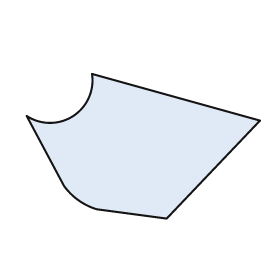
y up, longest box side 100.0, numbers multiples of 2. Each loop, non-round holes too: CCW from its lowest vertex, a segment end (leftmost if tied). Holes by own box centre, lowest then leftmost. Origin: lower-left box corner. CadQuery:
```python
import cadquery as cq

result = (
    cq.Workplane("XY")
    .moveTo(60.0, 0.0)
    .lineTo(100.0, 42.0)
    .lineTo(28.0, 62.0)
    .threePointArc((20.0, 44.0), (0.0, 44.0))
    .lineTo(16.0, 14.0)
    .threePointArc((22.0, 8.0), (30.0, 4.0))
    .close()
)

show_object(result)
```